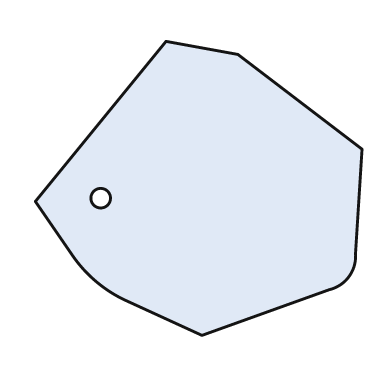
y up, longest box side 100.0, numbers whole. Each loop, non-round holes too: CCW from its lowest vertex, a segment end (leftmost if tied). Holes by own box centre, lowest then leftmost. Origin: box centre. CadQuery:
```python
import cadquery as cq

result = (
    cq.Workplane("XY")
    .moveTo(1.0, -45.0)
    .lineTo(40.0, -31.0)
    .threePointArc((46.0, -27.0), (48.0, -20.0))
    .lineTo(50.0, 12.0)
    .lineTo(12.0, 41.0)
    .lineTo(-10.0, 45.0)
    .lineTo(-50.0, -4.0)
    .lineTo(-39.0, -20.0)
    .threePointArc((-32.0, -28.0), (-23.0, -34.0))
    .close()
    .moveTo(-30.0, -3.0)
    .circle(3.0)
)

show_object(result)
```